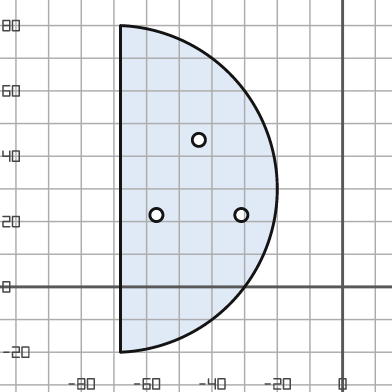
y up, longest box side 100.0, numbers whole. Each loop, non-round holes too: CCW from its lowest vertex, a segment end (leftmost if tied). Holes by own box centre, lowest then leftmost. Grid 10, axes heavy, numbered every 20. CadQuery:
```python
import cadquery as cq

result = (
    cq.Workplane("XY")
    .moveTo(-68.0, -20.0)
    .threePointArc((-20.0, 30.0), (-68.0, 80.0))
    .close()
    .moveTo(-57.0, 22.0)
    .circle(2.0)
    .moveTo(-31.0, 22.0)
    .circle(2.0)
    .moveTo(-44.0, 45.0)
    .circle(2.0)
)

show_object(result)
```